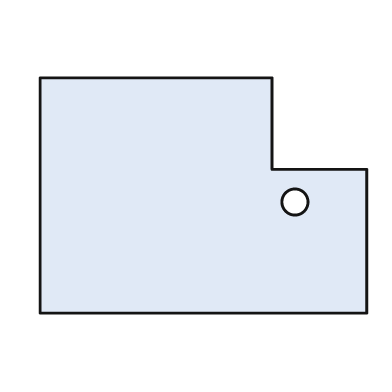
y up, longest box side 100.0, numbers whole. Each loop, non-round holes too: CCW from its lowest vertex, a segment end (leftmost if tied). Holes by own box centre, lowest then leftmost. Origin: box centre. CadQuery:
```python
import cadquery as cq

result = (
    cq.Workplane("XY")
    .moveTo(-50.0, -36.0)
    .lineTo(50.0, -36.0)
    .lineTo(50.0, 8.0)
    .lineTo(21.0, 8.0)
    .lineTo(21.0, 36.0)
    .lineTo(-50.0, 36.0)
    .close()
    .moveTo(28.0, -2.0)
    .circle(4.0)
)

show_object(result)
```